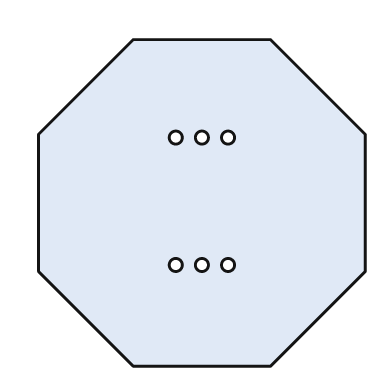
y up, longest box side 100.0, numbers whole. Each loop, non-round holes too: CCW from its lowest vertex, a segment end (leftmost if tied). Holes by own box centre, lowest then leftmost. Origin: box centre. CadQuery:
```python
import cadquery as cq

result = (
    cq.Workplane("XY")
    .moveTo(-21.0, -50.0)
    .lineTo(21.0, -50.0)
    .lineTo(50.0, -21.0)
    .lineTo(50.0, 21.0)
    .lineTo(21.0, 50.0)
    .lineTo(-21.0, 50.0)
    .lineTo(-50.0, 21.0)
    .lineTo(-50.0, -21.0)
    .close()
    .moveTo(-8.0, -19.0)
    .circle(2.0)
    .moveTo(0.0, -19.0)
    .circle(2.0)
    .moveTo(8.0, -19.0)
    .circle(2.0)
    .moveTo(-8.0, 20.0)
    .circle(2.0)
    .moveTo(0.0, 20.0)
    .circle(2.0)
    .moveTo(8.0, 20.0)
    .circle(2.0)
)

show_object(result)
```